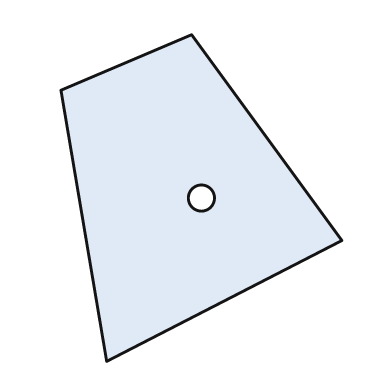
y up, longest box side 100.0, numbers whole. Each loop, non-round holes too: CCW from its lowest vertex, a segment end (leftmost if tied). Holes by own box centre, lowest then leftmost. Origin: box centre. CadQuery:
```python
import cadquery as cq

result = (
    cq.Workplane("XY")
    .moveTo(-29.0, -50.0)
    .lineTo(43.0, -13.0)
    .lineTo(-3.0, 50.0)
    .lineTo(-43.0, 33.0)
    .close()
    .moveTo(0.0, 0.0)
    .circle(4.0)
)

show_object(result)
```